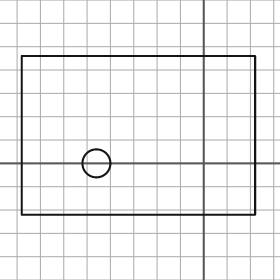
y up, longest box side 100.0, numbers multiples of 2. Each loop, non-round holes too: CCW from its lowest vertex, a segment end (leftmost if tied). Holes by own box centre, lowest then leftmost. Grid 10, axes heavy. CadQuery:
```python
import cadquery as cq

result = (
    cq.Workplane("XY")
    .moveTo(-78.0, -22.0)
    .lineTo(22.0, -22.0)
    .lineTo(22.0, 46.0)
    .lineTo(-78.0, 46.0)
    .close()
    .moveTo(-46.0, 0.0)
    .circle(6.0)
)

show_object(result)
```